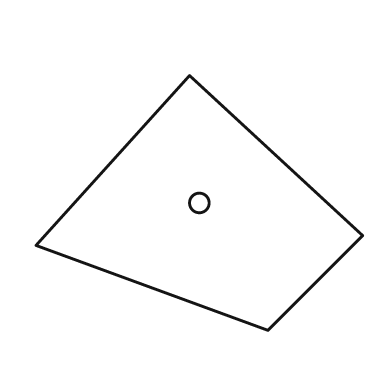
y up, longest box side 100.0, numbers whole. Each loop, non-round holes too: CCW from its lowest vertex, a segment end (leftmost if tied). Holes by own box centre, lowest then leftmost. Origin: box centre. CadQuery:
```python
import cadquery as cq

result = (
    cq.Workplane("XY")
    .moveTo(21.0, -39.0)
    .lineTo(50.0, -10.0)
    .lineTo(-3.0, 39.0)
    .lineTo(-50.0, -13.0)
    .close()
    .moveTo(0.0, 0.0)
    .circle(3.0)
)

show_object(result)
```